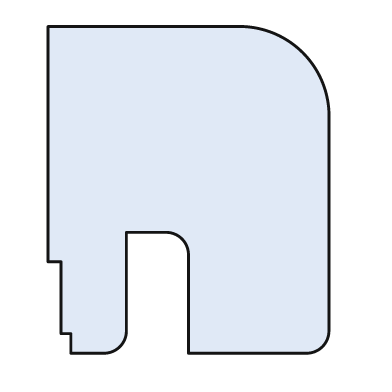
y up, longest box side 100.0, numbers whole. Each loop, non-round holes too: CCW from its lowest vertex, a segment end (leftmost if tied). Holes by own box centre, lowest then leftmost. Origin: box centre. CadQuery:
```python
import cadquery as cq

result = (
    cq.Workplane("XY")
    .moveTo(-36.0, -50.0)
    .lineTo(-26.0, -50.0)
    .threePointArc((-21.0, -48.0), (-19.0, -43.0))
    .lineTo(-19.0, -13.0)
    .lineTo(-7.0, -13.0)
    .threePointArc((-2.0, -15.0), (0.0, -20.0))
    .lineTo(0.0, -50.0)
    .lineTo(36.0, -50.0)
    .threePointArc((41.0, -48.0), (43.0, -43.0))
    .lineTo(43.0, 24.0)
    .threePointArc((35.0, 42.0), (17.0, 50.0))
    .lineTo(-43.0, 50.0)
    .lineTo(-43.0, -22.0)
    .lineTo(-39.0, -22.0)
    .lineTo(-39.0, -44.0)
    .lineTo(-36.0, -44.0)
    .close()
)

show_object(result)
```